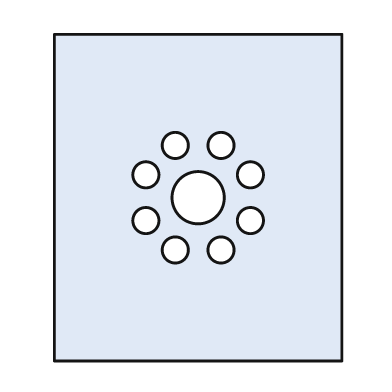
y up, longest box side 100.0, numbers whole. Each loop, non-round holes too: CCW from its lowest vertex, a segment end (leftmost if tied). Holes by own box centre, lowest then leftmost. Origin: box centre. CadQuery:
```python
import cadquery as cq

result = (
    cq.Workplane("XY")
    .moveTo(-44.0, -50.0)
    .lineTo(44.0, -50.0)
    .lineTo(44.0, 50.0)
    .lineTo(-44.0, 50.0)
    .close()
    .moveTo(-7.0, -16.0)
    .circle(4.0)
    .moveTo(7.0, -16.0)
    .circle(4.0)
    .moveTo(-16.0, -7.0)
    .circle(4.0)
    .moveTo(16.0, -7.0)
    .circle(4.0)
    .moveTo(0.0, 0.0)
    .circle(8.0)
    .moveTo(-16.0, 7.0)
    .circle(4.0)
    .moveTo(16.0, 7.0)
    .circle(4.0)
    .moveTo(-7.0, 16.0)
    .circle(4.0)
    .moveTo(7.0, 16.0)
    .circle(4.0)
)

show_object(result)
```